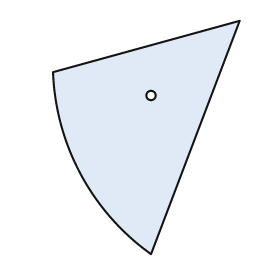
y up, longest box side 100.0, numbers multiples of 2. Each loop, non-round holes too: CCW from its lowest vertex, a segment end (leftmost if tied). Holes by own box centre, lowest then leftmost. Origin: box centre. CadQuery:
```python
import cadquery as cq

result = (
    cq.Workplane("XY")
    .moveTo(2.0, -50.0)
    .lineTo(40.0, 50.0)
    .lineTo(-40.0, 28.0)
    .threePointArc((-28.0, -16.0), (2.0, -50.0))
    .close()
    .moveTo(2.0, 18.0)
    .circle(2.0)
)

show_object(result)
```